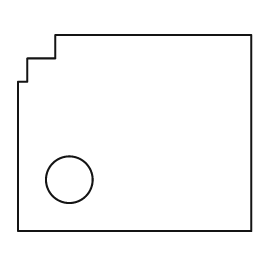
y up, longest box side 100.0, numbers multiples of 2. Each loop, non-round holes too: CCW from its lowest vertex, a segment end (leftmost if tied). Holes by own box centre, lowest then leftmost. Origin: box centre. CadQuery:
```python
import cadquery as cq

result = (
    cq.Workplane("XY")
    .moveTo(-50.0, -42.0)
    .lineTo(50.0, -42.0)
    .lineTo(50.0, 42.0)
    .lineTo(-34.0, 42.0)
    .lineTo(-34.0, 32.0)
    .lineTo(-46.0, 32.0)
    .lineTo(-46.0, 22.0)
    .lineTo(-50.0, 22.0)
    .close()
    .moveTo(-28.0, -20.0)
    .circle(10.0)
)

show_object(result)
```